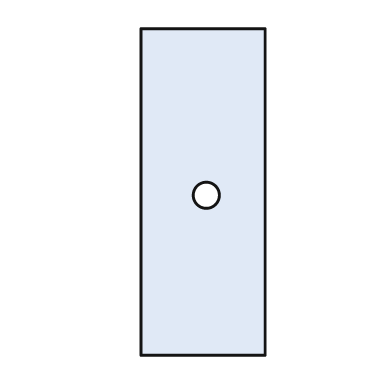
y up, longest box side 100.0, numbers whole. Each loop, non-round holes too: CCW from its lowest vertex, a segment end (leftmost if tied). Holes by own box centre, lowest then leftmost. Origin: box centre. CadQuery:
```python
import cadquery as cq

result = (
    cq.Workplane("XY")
    .moveTo(-19.0, -50.0)
    .lineTo(19.0, -50.0)
    .lineTo(19.0, 50.0)
    .lineTo(-19.0, 50.0)
    .close()
    .moveTo(1.0, -1.0)
    .circle(4.0)
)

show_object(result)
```